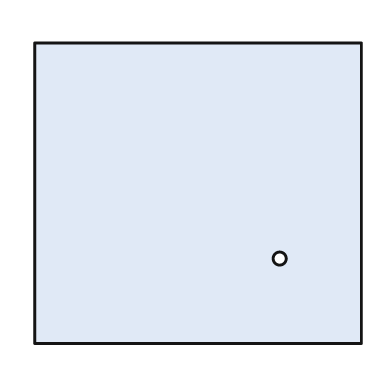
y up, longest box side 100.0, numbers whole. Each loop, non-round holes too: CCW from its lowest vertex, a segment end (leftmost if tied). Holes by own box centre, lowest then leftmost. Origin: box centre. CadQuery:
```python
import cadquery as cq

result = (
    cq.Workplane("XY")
    .moveTo(-50.0, -46.0)
    .lineTo(50.0, -46.0)
    .lineTo(50.0, 46.0)
    .lineTo(-50.0, 46.0)
    .close()
    .moveTo(25.0, -20.0)
    .circle(2.0)
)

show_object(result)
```